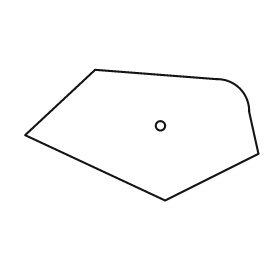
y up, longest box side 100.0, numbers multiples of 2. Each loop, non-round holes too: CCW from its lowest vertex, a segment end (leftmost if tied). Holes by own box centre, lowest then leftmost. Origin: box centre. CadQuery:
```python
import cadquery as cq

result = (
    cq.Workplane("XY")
    .moveTo(10.0, -28.0)
    .lineTo(50.0, -8.0)
    .lineTo(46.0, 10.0)
    .threePointArc((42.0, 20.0), (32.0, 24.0))
    .lineTo(-20.0, 28.0)
    .lineTo(-50.0, 0.0)
    .close()
    .moveTo(8.0, 4.0)
    .circle(2.0)
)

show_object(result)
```